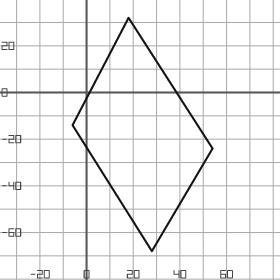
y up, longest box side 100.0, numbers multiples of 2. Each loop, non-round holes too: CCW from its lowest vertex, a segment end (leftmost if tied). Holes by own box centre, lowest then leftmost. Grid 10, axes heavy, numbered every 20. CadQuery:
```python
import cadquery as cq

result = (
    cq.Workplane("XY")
    .moveTo(28.0, -68.0)
    .lineTo(54.0, -24.0)
    .lineTo(18.0, 32.0)
    .lineTo(-6.0, -14.0)
    .close()
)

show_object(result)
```